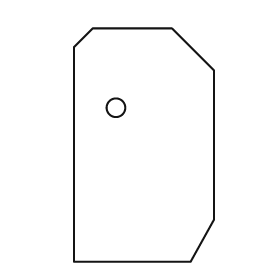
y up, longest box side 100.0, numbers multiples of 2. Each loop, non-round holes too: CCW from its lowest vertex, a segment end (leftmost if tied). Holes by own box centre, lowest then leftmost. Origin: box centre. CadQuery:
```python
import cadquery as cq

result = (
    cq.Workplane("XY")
    .moveTo(-30.0, -50.0)
    .lineTo(20.0, -50.0)
    .lineTo(30.0, -32.0)
    .lineTo(30.0, 32.0)
    .lineTo(12.0, 50.0)
    .lineTo(-22.0, 50.0)
    .lineTo(-30.0, 42.0)
    .close()
    .moveTo(-12.0, 16.0)
    .circle(4.0)
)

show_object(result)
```